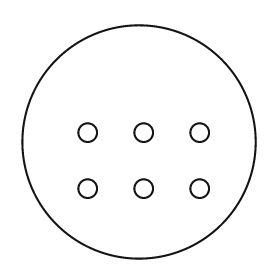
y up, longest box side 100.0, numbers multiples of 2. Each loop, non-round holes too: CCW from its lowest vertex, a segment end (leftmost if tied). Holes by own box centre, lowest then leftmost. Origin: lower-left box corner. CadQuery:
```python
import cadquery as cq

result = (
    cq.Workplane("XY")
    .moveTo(50.0, 50.0)
    .circle(50.0)
    .moveTo(28.0, 30.0)
    .circle(4.0)
    .moveTo(52.0, 30.0)
    .circle(4.0)
    .moveTo(76.0, 30.0)
    .circle(4.0)
    .moveTo(28.0, 54.0)
    .circle(4.0)
    .moveTo(52.0, 54.0)
    .circle(4.0)
    .moveTo(76.0, 54.0)
    .circle(4.0)
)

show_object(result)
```